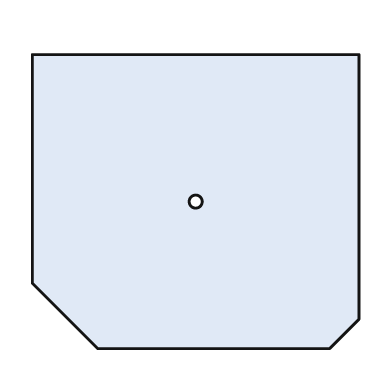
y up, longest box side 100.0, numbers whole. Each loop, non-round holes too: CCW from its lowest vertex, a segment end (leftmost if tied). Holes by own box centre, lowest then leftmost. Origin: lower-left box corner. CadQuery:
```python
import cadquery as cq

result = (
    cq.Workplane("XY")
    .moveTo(20.0, 0.0)
    .lineTo(91.0, 0.0)
    .lineTo(100.0, 9.0)
    .lineTo(100.0, 90.0)
    .lineTo(0.0, 90.0)
    .lineTo(0.0, 20.0)
    .close()
    .moveTo(50.0, 45.0)
    .circle(2.0)
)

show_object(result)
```